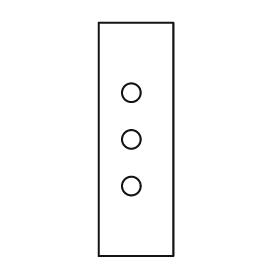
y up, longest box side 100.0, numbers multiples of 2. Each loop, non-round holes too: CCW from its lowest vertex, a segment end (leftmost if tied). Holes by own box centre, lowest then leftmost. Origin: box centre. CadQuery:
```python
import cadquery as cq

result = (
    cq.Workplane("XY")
    .moveTo(-16.0, -50.0)
    .lineTo(16.0, -50.0)
    .lineTo(16.0, 50.0)
    .lineTo(-16.0, 50.0)
    .close()
    .moveTo(-2.0, -20.0)
    .circle(4.0)
    .moveTo(-2.0, 0.0)
    .circle(4.0)
    .moveTo(-2.0, 20.0)
    .circle(4.0)
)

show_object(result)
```